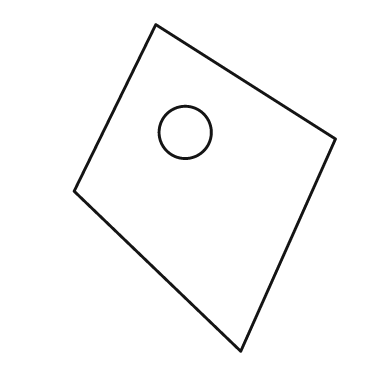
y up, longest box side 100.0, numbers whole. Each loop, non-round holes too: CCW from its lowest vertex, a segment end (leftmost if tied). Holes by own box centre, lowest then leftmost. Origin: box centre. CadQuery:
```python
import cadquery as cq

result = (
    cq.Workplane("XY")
    .moveTo(11.0, -50.0)
    .lineTo(40.0, 15.0)
    .lineTo(-15.0, 50.0)
    .lineTo(-40.0, -1.0)
    .close()
    .moveTo(-6.0, 17.0)
    .circle(8.0)
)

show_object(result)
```